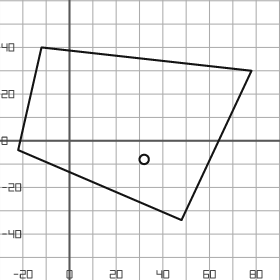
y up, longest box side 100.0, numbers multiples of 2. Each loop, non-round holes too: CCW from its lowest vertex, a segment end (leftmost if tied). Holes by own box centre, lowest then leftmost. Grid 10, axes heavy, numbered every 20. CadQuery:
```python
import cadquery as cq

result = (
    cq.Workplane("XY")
    .moveTo(48.0, -34.0)
    .lineTo(78.0, 30.0)
    .lineTo(-12.0, 40.0)
    .lineTo(-22.0, -4.0)
    .close()
    .moveTo(32.0, -8.0)
    .circle(2.0)
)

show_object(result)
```